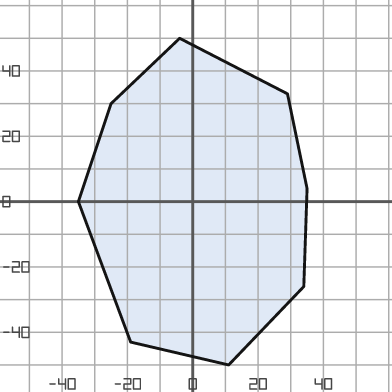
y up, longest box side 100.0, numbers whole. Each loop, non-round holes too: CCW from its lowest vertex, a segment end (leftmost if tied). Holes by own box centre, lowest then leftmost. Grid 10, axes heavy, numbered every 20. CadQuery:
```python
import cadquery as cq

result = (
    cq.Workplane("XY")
    .moveTo(11.0, -50.0)
    .lineTo(34.0, -26.0)
    .lineTo(35.0, 4.0)
    .lineTo(29.0, 33.0)
    .lineTo(-4.0, 50.0)
    .lineTo(-25.0, 30.0)
    .lineTo(-35.0, 0.0)
    .lineTo(-19.0, -43.0)
    .close()
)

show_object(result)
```